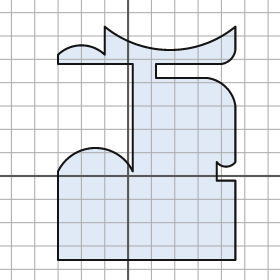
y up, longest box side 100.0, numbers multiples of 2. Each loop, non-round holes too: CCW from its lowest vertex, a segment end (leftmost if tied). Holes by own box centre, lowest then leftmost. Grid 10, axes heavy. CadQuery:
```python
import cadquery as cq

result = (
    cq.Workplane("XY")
    .moveTo(-30.0, -36.0)
    .lineTo(46.0, -36.0)
    .lineTo(46.0, -2.0)
    .lineTo(38.0, -2.0)
    .lineTo(38.0, 6.0)
    .threePointArc((42.0, 4.0), (46.0, 6.0))
    .lineTo(46.0, 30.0)
    .threePointArc((42.0, 38.0), (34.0, 42.0))
    .lineTo(12.0, 42.0)
    .lineTo(12.0, 48.0)
    .lineTo(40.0, 48.0)
    .threePointArc((44.0, 50.0), (46.0, 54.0))
    .lineTo(46.0, 64.0)
    .threePointArc((18.0, 54.0), (-10.0, 64.0))
    .lineTo(-10.0, 52.0)
    .threePointArc((-20.0, 56.0), (-30.0, 52.0))
    .lineTo(-30.0, 48.0)
    .lineTo(2.0, 48.0)
    .lineTo(2.0, 2.0)
    .threePointArc((-14.0, 12.0), (-30.0, 2.0))
    .close()
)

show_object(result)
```